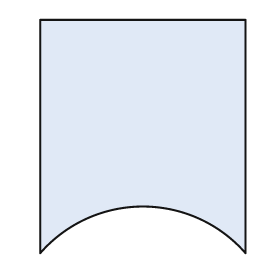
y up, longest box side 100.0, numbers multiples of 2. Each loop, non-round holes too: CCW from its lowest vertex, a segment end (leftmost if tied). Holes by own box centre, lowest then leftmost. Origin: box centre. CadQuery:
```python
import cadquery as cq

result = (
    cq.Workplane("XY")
    .moveTo(-44.0, -50.0)
    .threePointArc((0.0, -30.0), (44.0, -50.0))
    .lineTo(44.0, 50.0)
    .lineTo(-44.0, 50.0)
    .close()
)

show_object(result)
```